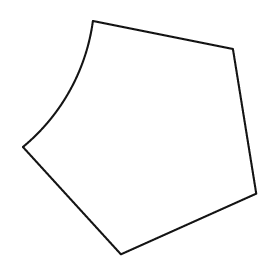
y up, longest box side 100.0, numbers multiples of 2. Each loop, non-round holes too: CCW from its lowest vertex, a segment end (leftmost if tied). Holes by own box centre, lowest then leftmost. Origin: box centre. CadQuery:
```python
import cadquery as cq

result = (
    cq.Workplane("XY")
    .moveTo(-8.0, -50.0)
    .lineTo(50.0, -24.0)
    .lineTo(40.0, 38.0)
    .lineTo(-20.0, 50.0)
    .threePointArc((-30.0, 20.0), (-50.0, -4.0))
    .close()
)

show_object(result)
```